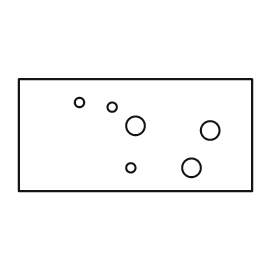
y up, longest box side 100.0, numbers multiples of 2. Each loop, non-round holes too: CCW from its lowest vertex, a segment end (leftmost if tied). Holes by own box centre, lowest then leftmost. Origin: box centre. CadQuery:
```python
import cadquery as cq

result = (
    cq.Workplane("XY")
    .moveTo(-50.0, -24.0)
    .lineTo(50.0, -24.0)
    .lineTo(50.0, 24.0)
    .lineTo(-50.0, 24.0)
    .close()
    .moveTo(-2.0, -14.0)
    .circle(2.0)
    .moveTo(24.0, -14.0)
    .circle(4.0)
    .moveTo(32.0, 2.0)
    .circle(4.0)
    .moveTo(0.0, 4.0)
    .circle(4.0)
    .moveTo(-10.0, 12.0)
    .circle(2.0)
    .moveTo(-24.0, 14.0)
    .circle(2.0)
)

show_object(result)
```